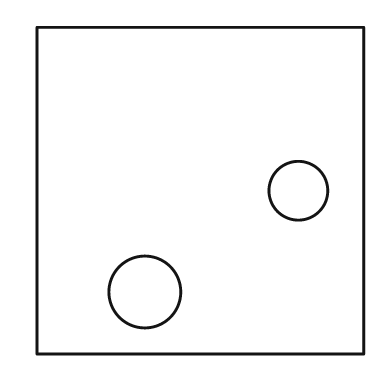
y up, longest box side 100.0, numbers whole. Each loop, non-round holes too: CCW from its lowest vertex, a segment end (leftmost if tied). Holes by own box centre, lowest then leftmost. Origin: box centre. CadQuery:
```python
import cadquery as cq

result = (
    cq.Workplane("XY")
    .moveTo(-50.0, -50.0)
    .lineTo(50.0, -50.0)
    .lineTo(50.0, 50.0)
    .lineTo(-50.0, 50.0)
    .close()
    .moveTo(-17.0, -31.0)
    .circle(11.0)
    .moveTo(30.0, 0.0)
    .circle(9.0)
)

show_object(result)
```